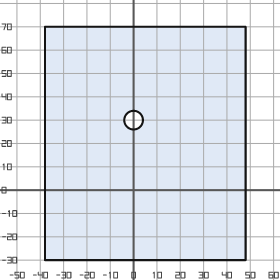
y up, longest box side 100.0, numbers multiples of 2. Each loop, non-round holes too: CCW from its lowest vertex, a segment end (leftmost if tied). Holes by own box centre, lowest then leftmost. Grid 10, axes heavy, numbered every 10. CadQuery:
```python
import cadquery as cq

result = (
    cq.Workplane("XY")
    .moveTo(-38.0, -30.0)
    .lineTo(48.0, -30.0)
    .lineTo(48.0, 70.0)
    .lineTo(-38.0, 70.0)
    .close()
    .moveTo(0.0, 30.0)
    .circle(4.0)
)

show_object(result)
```